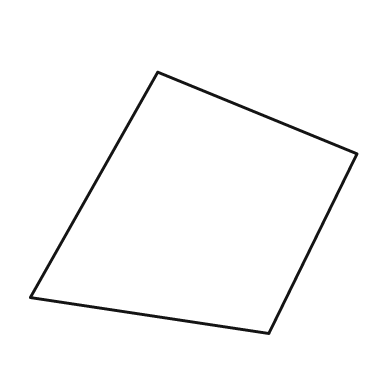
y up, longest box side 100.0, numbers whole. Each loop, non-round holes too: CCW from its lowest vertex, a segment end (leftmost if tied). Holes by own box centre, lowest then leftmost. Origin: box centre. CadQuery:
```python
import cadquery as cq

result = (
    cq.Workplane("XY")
    .moveTo(23.0, -40.0)
    .lineTo(50.0, 15.0)
    .lineTo(-11.0, 40.0)
    .lineTo(-50.0, -29.0)
    .close()
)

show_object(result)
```